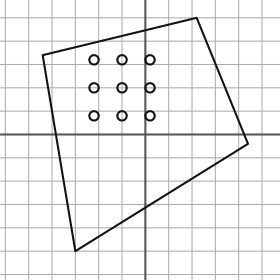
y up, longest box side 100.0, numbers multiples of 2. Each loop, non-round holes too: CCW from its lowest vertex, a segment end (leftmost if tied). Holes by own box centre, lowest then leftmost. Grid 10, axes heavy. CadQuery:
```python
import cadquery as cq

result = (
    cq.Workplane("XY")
    .moveTo(-30.0, -50.0)
    .lineTo(44.0, -4.0)
    .lineTo(22.0, 50.0)
    .lineTo(-44.0, 34.0)
    .close()
    .moveTo(-22.0, 8.0)
    .circle(2.0)
    .moveTo(-10.0, 8.0)
    .circle(2.0)
    .moveTo(2.0, 8.0)
    .circle(2.0)
    .moveTo(-22.0, 20.0)
    .circle(2.0)
    .moveTo(-10.0, 20.0)
    .circle(2.0)
    .moveTo(2.0, 20.0)
    .circle(2.0)
    .moveTo(-22.0, 32.0)
    .circle(2.0)
    .moveTo(-10.0, 32.0)
    .circle(2.0)
    .moveTo(2.0, 32.0)
    .circle(2.0)
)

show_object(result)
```